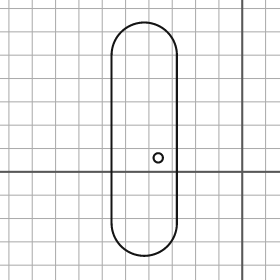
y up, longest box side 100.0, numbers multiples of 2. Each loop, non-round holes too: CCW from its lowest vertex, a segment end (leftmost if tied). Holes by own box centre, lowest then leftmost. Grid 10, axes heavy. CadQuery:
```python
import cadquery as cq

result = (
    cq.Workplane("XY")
    .moveTo(-56.0, -22.0)
    .threePointArc((-42.0, -36.0), (-28.0, -22.0))
    .lineTo(-28.0, 50.0)
    .threePointArc((-42.0, 64.0), (-56.0, 50.0))
    .close()
    .moveTo(-36.0, 6.0)
    .circle(2.0)
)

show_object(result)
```